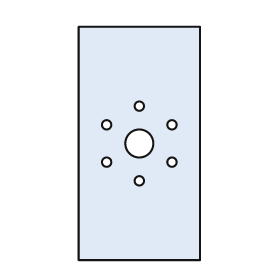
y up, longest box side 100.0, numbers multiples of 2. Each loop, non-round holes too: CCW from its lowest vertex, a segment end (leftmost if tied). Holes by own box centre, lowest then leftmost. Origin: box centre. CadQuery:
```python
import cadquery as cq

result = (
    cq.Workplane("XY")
    .moveTo(-26.0, -50.0)
    .lineTo(26.0, -50.0)
    .lineTo(26.0, 50.0)
    .lineTo(-26.0, 50.0)
    .close()
    .moveTo(0.0, -16.0)
    .circle(2.0)
    .moveTo(-14.0, -8.0)
    .circle(2.0)
    .moveTo(14.0, -8.0)
    .circle(2.0)
    .moveTo(0.0, 0.0)
    .circle(6.0)
    .moveTo(-14.0, 8.0)
    .circle(2.0)
    .moveTo(14.0, 8.0)
    .circle(2.0)
    .moveTo(0.0, 16.0)
    .circle(2.0)
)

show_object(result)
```